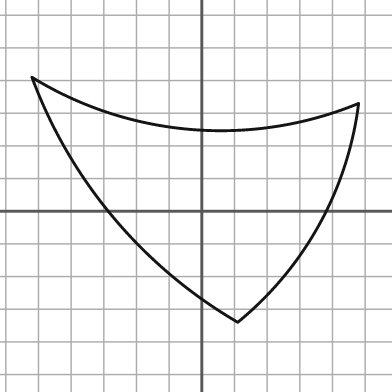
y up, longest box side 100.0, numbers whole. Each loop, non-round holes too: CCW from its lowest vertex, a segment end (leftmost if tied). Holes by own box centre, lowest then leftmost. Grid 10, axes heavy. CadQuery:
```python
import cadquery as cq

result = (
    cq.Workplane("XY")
    .moveTo(11.0, -34.0)
    .threePointArc((36.0, -4.0), (48.0, 33.0))
    .threePointArc((-3.0, 25.0), (-52.0, 41.0))
    .threePointArc((-27.0, -2.0), (11.0, -34.0))
    .close()
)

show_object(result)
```